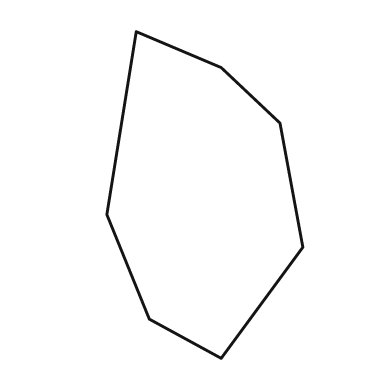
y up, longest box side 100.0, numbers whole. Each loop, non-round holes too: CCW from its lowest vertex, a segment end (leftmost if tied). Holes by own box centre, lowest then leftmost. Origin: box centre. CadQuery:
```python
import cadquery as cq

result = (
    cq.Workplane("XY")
    .moveTo(5.0, -50.0)
    .lineTo(30.0, -16.0)
    .lineTo(23.0, 22.0)
    .lineTo(5.0, 39.0)
    .lineTo(-21.0, 50.0)
    .lineTo(-30.0, -6.0)
    .lineTo(-17.0, -38.0)
    .close()
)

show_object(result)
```